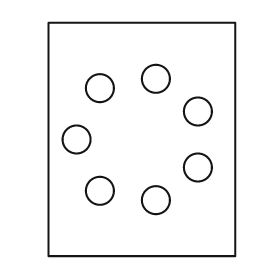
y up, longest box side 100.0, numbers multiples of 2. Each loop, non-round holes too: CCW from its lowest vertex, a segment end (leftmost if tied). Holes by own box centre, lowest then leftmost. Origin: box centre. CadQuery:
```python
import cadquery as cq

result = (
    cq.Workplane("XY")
    .moveTo(-40.0, -50.0)
    .lineTo(40.0, -50.0)
    .lineTo(40.0, 50.0)
    .lineTo(-40.0, 50.0)
    .close()
    .moveTo(6.0, -26.0)
    .circle(6.0)
    .moveTo(-18.0, -22.0)
    .circle(6.0)
    .moveTo(24.0, -12.0)
    .circle(6.0)
    .moveTo(-28.0, 0.0)
    .circle(6.0)
    .moveTo(24.0, 12.0)
    .circle(6.0)
    .moveTo(-18.0, 22.0)
    .circle(6.0)
    .moveTo(6.0, 26.0)
    .circle(6.0)
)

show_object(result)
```